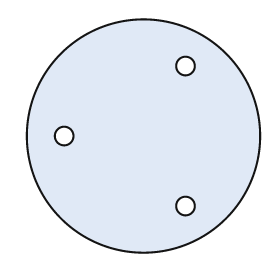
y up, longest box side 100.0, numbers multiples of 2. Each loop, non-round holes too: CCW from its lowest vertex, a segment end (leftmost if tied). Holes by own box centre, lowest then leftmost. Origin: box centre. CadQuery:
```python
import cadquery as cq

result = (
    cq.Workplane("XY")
    .moveTo(0.0, 0.0)
    .circle(50.0)
    .moveTo(18.0, -30.0)
    .circle(4.0)
    .moveTo(-34.0, 0.0)
    .circle(4.0)
    .moveTo(18.0, 30.0)
    .circle(4.0)
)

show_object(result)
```